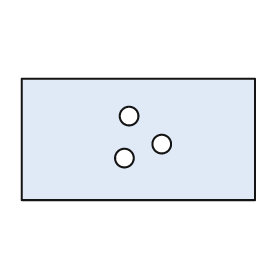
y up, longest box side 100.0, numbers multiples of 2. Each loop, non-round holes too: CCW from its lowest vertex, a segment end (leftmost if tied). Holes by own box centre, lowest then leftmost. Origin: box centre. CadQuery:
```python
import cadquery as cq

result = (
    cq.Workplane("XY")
    .moveTo(-50.0, -26.0)
    .lineTo(50.0, -26.0)
    .lineTo(50.0, 26.0)
    .lineTo(-50.0, 26.0)
    .close()
    .moveTo(-6.0, -8.0)
    .circle(4.0)
    .moveTo(10.0, -2.0)
    .circle(4.0)
    .moveTo(-4.0, 10.0)
    .circle(4.0)
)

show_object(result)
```